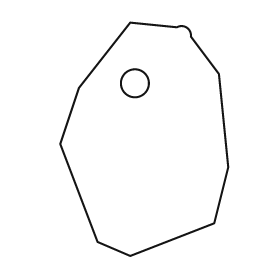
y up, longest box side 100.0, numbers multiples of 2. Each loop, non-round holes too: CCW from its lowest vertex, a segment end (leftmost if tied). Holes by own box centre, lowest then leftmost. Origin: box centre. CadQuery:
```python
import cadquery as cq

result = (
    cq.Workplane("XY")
    .moveTo(-6.0, -50.0)
    .lineTo(30.0, -36.0)
    .lineTo(36.0, -12.0)
    .lineTo(32.0, 28.0)
    .lineTo(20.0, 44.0)
    .threePointArc((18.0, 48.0), (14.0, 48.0))
    .lineTo(-6.0, 50.0)
    .lineTo(-28.0, 22.0)
    .lineTo(-36.0, -2.0)
    .lineTo(-20.0, -44.0)
    .close()
    .moveTo(-4.0, 24.0)
    .circle(6.0)
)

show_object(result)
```